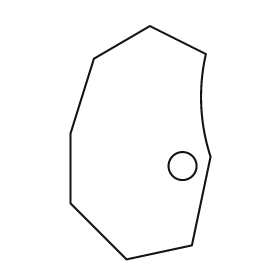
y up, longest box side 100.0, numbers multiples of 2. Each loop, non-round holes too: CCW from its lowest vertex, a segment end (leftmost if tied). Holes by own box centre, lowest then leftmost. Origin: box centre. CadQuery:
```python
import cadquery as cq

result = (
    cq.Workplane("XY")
    .moveTo(-6.0, -50.0)
    .lineTo(22.0, -44.0)
    .lineTo(30.0, -6.0)
    .threePointArc((26.0, 16.0), (28.0, 38.0))
    .lineTo(4.0, 50.0)
    .lineTo(-20.0, 36.0)
    .lineTo(-30.0, 4.0)
    .lineTo(-30.0, -26.0)
    .close()
    .moveTo(18.0, -10.0)
    .circle(6.0)
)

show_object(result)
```